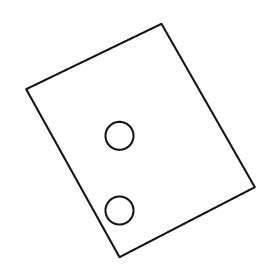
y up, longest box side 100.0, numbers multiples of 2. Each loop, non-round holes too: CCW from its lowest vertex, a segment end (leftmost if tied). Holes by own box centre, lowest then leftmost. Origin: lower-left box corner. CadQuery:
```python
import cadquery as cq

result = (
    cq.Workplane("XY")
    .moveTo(40.0, 0.0)
    .lineTo(98.0, 30.0)
    .lineTo(58.0, 100.0)
    .lineTo(0.0, 72.0)
    .close()
    .moveTo(40.0, 20.0)
    .circle(6.0)
    .moveTo(40.0, 52.0)
    .circle(6.0)
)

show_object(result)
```